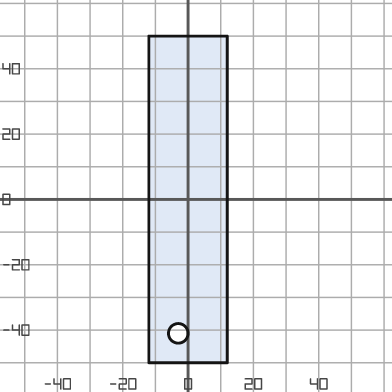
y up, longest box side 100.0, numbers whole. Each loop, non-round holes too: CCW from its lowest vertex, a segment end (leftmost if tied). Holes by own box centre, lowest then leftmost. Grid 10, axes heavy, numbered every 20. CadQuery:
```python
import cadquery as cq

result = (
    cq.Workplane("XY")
    .moveTo(-12.0, -50.0)
    .lineTo(12.0, -50.0)
    .lineTo(12.0, 50.0)
    .lineTo(-12.0, 50.0)
    .close()
    .moveTo(-3.0, -41.0)
    .circle(3.0)
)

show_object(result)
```